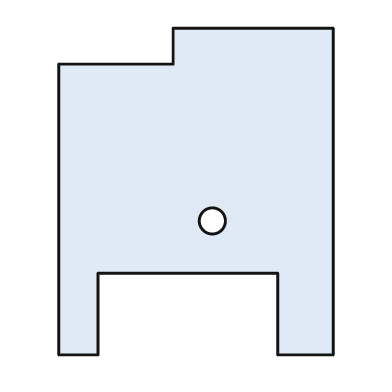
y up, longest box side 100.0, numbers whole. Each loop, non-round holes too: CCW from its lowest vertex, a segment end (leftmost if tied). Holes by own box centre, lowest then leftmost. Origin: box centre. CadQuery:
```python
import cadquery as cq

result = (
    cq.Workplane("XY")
    .moveTo(-42.0, -50.0)
    .lineTo(-30.0, -50.0)
    .lineTo(-30.0, -25.0)
    .lineTo(25.0, -25.0)
    .lineTo(25.0, -50.0)
    .lineTo(42.0, -50.0)
    .lineTo(42.0, 50.0)
    .lineTo(-7.0, 50.0)
    .lineTo(-7.0, 39.0)
    .lineTo(-42.0, 39.0)
    .close()
    .moveTo(5.0, -9.0)
    .circle(4.0)
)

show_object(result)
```